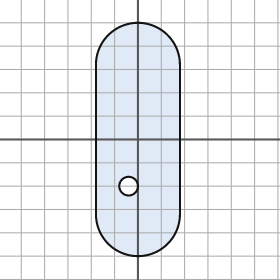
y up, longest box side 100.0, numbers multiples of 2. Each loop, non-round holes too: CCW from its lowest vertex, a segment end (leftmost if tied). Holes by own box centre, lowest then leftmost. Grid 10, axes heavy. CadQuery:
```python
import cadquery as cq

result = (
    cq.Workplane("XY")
    .moveTo(-18.0, -32.0)
    .threePointArc((0.0, -50.0), (18.0, -32.0))
    .lineTo(18.0, 32.0)
    .threePointArc((0.0, 50.0), (-18.0, 32.0))
    .close()
    .moveTo(-4.0, -20.0)
    .circle(4.0)
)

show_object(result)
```